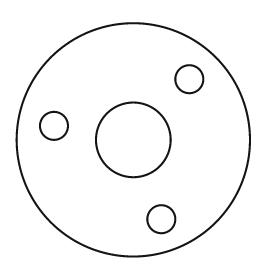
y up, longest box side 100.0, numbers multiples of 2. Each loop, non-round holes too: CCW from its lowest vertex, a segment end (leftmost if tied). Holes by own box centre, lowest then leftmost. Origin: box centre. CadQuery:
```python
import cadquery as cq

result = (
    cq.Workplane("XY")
    .moveTo(0.0, 0.0)
    .circle(50.0)
    .moveTo(12.0, -34.0)
    .circle(6.0)
    .moveTo(0.0, 0.0)
    .circle(16.0)
    .moveTo(-34.0, 6.0)
    .circle(6.0)
    .moveTo(24.0, 26.0)
    .circle(6.0)
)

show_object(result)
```